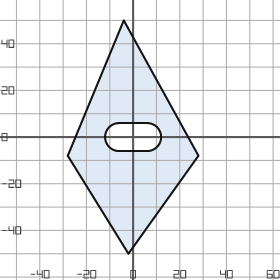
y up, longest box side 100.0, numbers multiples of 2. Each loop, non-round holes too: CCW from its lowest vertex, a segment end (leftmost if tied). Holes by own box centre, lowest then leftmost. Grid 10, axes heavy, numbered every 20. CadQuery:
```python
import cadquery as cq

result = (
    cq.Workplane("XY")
    .moveTo(-2.0, -50.0)
    .lineTo(28.0, -8.0)
    .lineTo(-4.0, 50.0)
    .lineTo(-28.0, -8.0)
    .close()
    .moveTo(-6.0, -6.0)
    .lineTo(6.0, -6.0)
    .threePointArc((12.0, 0.0), (6.0, 6.0))
    .lineTo(-6.0, 6.0)
    .threePointArc((-12.0, 0.0), (-6.0, -6.0))
    .close()
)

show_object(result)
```